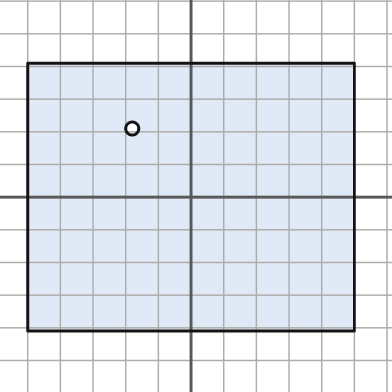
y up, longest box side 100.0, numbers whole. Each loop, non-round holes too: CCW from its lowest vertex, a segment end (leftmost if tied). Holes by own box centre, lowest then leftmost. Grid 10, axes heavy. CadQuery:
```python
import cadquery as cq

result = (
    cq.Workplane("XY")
    .moveTo(-50.0, -41.0)
    .lineTo(50.0, -41.0)
    .lineTo(50.0, 41.0)
    .lineTo(-50.0, 41.0)
    .close()
    .moveTo(-18.0, 21.0)
    .circle(2.0)
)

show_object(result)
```